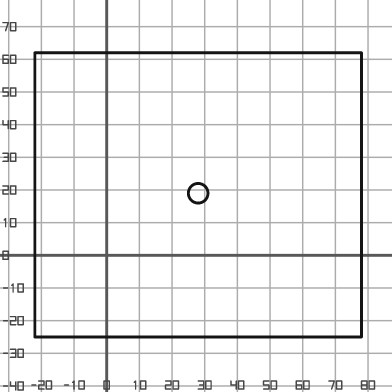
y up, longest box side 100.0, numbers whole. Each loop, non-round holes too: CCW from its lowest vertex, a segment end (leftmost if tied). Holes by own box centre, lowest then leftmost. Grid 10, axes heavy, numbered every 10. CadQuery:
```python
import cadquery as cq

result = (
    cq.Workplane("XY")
    .moveTo(-22.0, -25.0)
    .lineTo(78.0, -25.0)
    .lineTo(78.0, 62.0)
    .lineTo(-22.0, 62.0)
    .close()
    .moveTo(28.0, 19.0)
    .circle(3.0)
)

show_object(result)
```